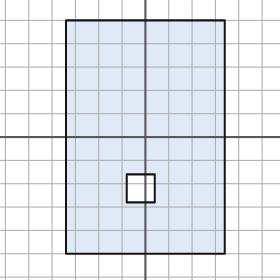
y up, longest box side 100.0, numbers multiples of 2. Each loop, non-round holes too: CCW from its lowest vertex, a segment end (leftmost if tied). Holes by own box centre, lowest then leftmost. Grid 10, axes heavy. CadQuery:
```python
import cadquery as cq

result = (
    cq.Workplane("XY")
    .moveTo(-34.0, -50.0)
    .lineTo(34.0, -50.0)
    .lineTo(34.0, 50.0)
    .lineTo(-34.0, 50.0)
    .close()
    .moveTo(-8.0, -28.0)
    .lineTo(4.0, -28.0)
    .lineTo(4.0, -16.0)
    .lineTo(-8.0, -16.0)
    .close()
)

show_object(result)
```